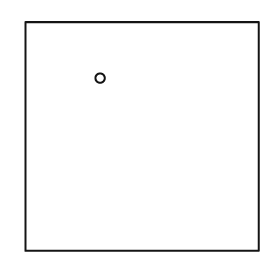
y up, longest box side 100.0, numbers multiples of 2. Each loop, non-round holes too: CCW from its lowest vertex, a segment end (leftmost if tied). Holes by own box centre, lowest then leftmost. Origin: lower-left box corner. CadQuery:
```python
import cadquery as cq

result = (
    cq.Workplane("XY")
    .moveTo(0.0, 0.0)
    .lineTo(100.0, 0.0)
    .lineTo(100.0, 98.0)
    .lineTo(0.0, 98.0)
    .close()
    .moveTo(32.0, 74.0)
    .circle(2.0)
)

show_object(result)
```